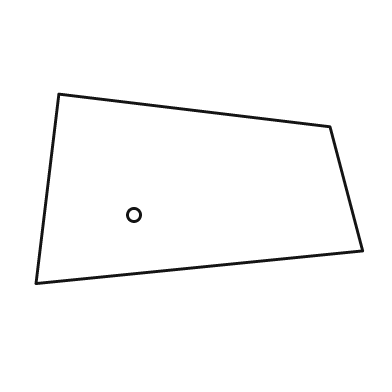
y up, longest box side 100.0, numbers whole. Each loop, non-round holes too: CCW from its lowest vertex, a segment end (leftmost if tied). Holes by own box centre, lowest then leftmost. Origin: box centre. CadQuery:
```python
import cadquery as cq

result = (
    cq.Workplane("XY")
    .moveTo(-50.0, -29.0)
    .lineTo(50.0, -19.0)
    .lineTo(40.0, 19.0)
    .lineTo(-43.0, 29.0)
    .close()
    .moveTo(-20.0, -8.0)
    .circle(2.0)
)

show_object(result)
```